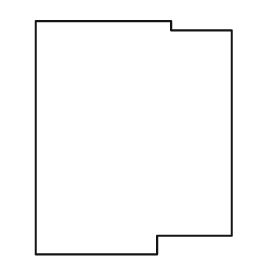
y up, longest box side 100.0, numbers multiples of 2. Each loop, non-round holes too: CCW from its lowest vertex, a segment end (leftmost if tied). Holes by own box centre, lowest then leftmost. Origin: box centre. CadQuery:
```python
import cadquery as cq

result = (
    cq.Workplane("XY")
    .moveTo(-42.0, -50.0)
    .lineTo(10.0, -50.0)
    .lineTo(10.0, -42.0)
    .lineTo(42.0, -42.0)
    .lineTo(42.0, 46.0)
    .lineTo(16.0, 46.0)
    .lineTo(16.0, 50.0)
    .lineTo(-42.0, 50.0)
    .close()
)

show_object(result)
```